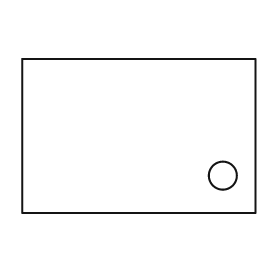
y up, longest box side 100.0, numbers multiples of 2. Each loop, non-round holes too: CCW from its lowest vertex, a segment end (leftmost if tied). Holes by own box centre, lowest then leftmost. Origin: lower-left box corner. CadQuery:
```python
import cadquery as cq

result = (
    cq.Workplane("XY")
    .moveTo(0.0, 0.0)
    .lineTo(100.0, 0.0)
    .lineTo(100.0, 66.0)
    .lineTo(0.0, 66.0)
    .close()
    .moveTo(86.0, 16.0)
    .circle(6.0)
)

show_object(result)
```